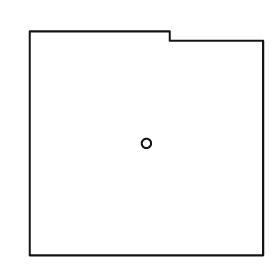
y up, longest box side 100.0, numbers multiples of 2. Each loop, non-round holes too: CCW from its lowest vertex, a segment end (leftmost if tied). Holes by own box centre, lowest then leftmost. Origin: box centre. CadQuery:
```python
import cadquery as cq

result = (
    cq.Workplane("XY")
    .moveTo(-50.0, -48.0)
    .lineTo(50.0, -48.0)
    .lineTo(50.0, 44.0)
    .lineTo(10.0, 44.0)
    .lineTo(10.0, 48.0)
    .lineTo(-50.0, 48.0)
    .close()
    .moveTo(0.0, 0.0)
    .circle(2.0)
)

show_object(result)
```